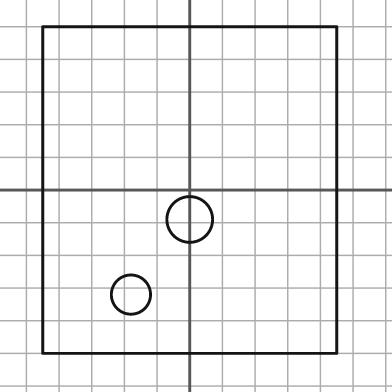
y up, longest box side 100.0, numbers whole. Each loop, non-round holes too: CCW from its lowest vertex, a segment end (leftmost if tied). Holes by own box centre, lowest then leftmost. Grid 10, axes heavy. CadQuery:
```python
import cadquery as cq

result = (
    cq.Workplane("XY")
    .moveTo(-45.0, -50.0)
    .lineTo(45.0, -50.0)
    .lineTo(45.0, 50.0)
    .lineTo(-45.0, 50.0)
    .close()
    .moveTo(-18.0, -32.0)
    .circle(6.0)
    .moveTo(0.0, -9.0)
    .circle(7.0)
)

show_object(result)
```